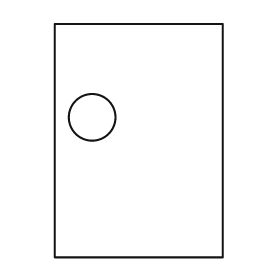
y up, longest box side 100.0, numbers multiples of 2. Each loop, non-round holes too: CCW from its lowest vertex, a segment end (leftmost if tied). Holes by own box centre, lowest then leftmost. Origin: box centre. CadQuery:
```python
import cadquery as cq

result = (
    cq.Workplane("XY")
    .moveTo(-36.0, -50.0)
    .lineTo(36.0, -50.0)
    .lineTo(36.0, 50.0)
    .lineTo(-36.0, 50.0)
    .close()
    .moveTo(-20.0, 10.0)
    .circle(10.0)
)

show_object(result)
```